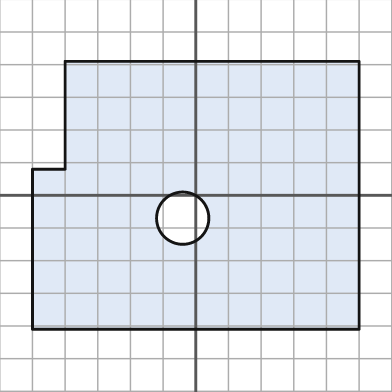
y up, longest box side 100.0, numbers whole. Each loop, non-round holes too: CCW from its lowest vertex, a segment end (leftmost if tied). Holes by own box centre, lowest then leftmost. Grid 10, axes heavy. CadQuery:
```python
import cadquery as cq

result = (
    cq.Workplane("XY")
    .moveTo(-50.0, -41.0)
    .lineTo(50.0, -41.0)
    .lineTo(50.0, 41.0)
    .lineTo(-40.0, 41.0)
    .lineTo(-40.0, 8.0)
    .lineTo(-50.0, 8.0)
    .close()
    .moveTo(-4.0, -7.0)
    .circle(8.0)
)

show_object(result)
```